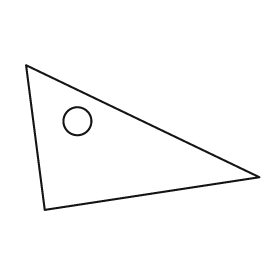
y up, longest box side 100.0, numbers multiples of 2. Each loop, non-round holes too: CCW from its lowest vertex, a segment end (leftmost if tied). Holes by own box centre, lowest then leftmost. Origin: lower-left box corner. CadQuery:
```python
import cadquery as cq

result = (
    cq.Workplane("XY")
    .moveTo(8.0, 0.0)
    .lineTo(100.0, 14.0)
    .lineTo(0.0, 62.0)
    .close()
    .moveTo(22.0, 38.0)
    .circle(6.0)
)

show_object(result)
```